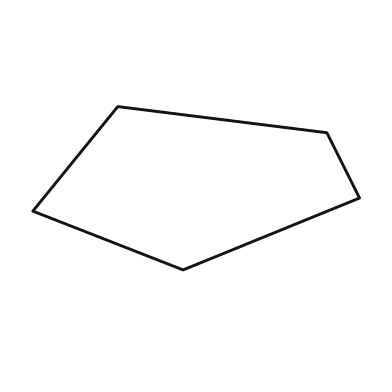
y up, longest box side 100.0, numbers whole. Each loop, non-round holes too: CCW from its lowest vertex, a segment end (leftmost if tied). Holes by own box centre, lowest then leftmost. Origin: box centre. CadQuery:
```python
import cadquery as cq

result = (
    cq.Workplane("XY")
    .moveTo(-4.0, -25.0)
    .lineTo(50.0, -3.0)
    .lineTo(40.0, 17.0)
    .lineTo(-24.0, 25.0)
    .lineTo(-50.0, -7.0)
    .close()
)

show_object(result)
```